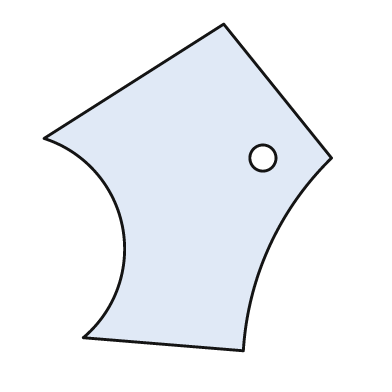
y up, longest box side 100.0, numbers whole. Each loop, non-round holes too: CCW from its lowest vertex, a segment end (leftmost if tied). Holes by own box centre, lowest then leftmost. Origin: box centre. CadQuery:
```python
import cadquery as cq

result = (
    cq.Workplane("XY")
    .moveTo(17.0, -50.0)
    .threePointArc((25.0, -18.0), (44.0, 9.0))
    .lineTo(11.0, 50.0)
    .lineTo(-44.0, 15.0)
    .threePointArc((-20.0, -12.0), (-32.0, -46.0))
    .close()
    .moveTo(23.0, 9.0)
    .circle(4.0)
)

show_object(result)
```